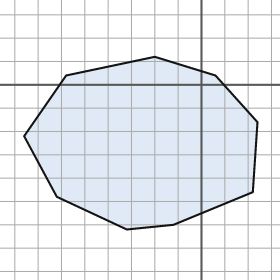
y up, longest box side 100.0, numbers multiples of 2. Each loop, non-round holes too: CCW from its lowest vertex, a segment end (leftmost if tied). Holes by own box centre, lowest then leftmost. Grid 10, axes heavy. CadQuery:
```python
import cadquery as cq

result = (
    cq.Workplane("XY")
    .moveTo(-32.0, -62.0)
    .lineTo(-12.0, -60.0)
    .lineTo(22.0, -46.0)
    .lineTo(24.0, -16.0)
    .lineTo(6.0, 4.0)
    .lineTo(-20.0, 12.0)
    .lineTo(-58.0, 4.0)
    .lineTo(-76.0, -22.0)
    .lineTo(-62.0, -48.0)
    .close()
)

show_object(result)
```